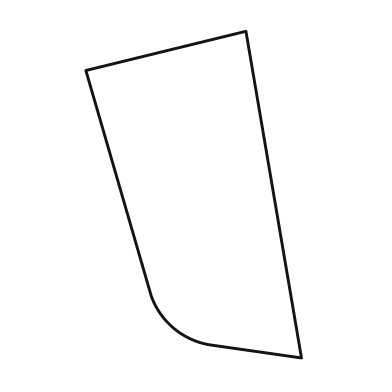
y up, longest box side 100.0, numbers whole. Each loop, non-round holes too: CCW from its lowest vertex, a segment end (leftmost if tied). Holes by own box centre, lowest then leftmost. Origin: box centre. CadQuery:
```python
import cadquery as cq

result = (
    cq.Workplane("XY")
    .moveTo(33.0, -50.0)
    .lineTo(16.0, 50.0)
    .lineTo(-33.0, 38.0)
    .lineTo(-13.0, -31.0)
    .threePointArc((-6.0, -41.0), (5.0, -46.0))
    .close()
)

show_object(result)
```